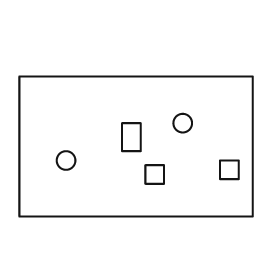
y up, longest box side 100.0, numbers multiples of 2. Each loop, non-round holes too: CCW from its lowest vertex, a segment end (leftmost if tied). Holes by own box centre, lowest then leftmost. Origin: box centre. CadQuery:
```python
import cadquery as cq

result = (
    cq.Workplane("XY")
    .moveTo(-50.0, -30.0)
    .lineTo(50.0, -30.0)
    .lineTo(50.0, 30.0)
    .lineTo(-50.0, 30.0)
    .close()
    .moveTo(4.0, -16.0)
    .lineTo(12.0, -16.0)
    .lineTo(12.0, -8.0)
    .lineTo(4.0, -8.0)
    .close()
    .moveTo(36.0, -14.0)
    .lineTo(44.0, -14.0)
    .lineTo(44.0, -6.0)
    .lineTo(36.0, -6.0)
    .close()
    .moveTo(-30.0, -6.0)
    .circle(4.0)
    .moveTo(-6.0, -2.0)
    .lineTo(2.0, -2.0)
    .lineTo(2.0, 10.0)
    .lineTo(-6.0, 10.0)
    .close()
    .moveTo(20.0, 10.0)
    .circle(4.0)
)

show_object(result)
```